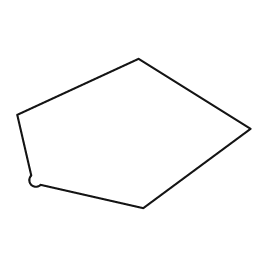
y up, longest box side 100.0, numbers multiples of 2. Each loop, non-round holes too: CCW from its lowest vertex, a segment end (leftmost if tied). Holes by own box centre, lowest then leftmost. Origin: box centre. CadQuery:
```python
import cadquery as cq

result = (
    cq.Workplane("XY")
    .moveTo(4.0, -32.0)
    .lineTo(50.0, 2.0)
    .lineTo(2.0, 32.0)
    .lineTo(-50.0, 8.0)
    .lineTo(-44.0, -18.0)
    .threePointArc((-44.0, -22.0), (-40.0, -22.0))
    .close()
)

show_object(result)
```